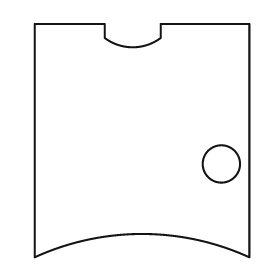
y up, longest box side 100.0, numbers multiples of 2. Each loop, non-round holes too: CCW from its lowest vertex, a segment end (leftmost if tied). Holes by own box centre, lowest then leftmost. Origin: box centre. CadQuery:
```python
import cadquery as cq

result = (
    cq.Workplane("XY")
    .moveTo(-46.0, -50.0)
    .threePointArc((0.0, -40.0), (46.0, -50.0))
    .lineTo(46.0, 50.0)
    .lineTo(8.0, 50.0)
    .lineTo(8.0, 44.0)
    .threePointArc((-4.0, 40.0), (-16.0, 44.0))
    .lineTo(-16.0, 50.0)
    .lineTo(-46.0, 50.0)
    .close()
    .moveTo(34.0, -10.0)
    .circle(8.0)
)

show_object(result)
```